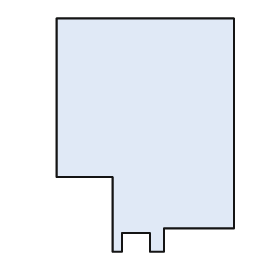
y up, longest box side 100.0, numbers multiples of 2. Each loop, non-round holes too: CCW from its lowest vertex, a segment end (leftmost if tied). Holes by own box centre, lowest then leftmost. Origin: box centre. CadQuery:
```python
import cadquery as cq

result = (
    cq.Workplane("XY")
    .moveTo(-14.0, -50.0)
    .lineTo(-10.0, -50.0)
    .lineTo(-10.0, -42.0)
    .lineTo(2.0, -42.0)
    .lineTo(2.0, -50.0)
    .lineTo(8.0, -50.0)
    .lineTo(8.0, -40.0)
    .lineTo(38.0, -40.0)
    .lineTo(38.0, 50.0)
    .lineTo(-38.0, 50.0)
    .lineTo(-38.0, -18.0)
    .lineTo(-14.0, -18.0)
    .close()
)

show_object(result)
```